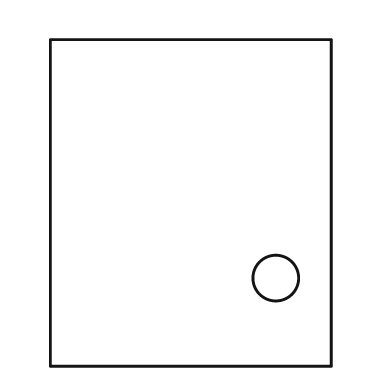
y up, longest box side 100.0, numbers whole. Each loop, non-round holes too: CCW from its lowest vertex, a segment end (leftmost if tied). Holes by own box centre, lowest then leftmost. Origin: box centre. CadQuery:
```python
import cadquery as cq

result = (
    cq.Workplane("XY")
    .moveTo(-43.0, -50.0)
    .lineTo(43.0, -50.0)
    .lineTo(43.0, 50.0)
    .lineTo(-43.0, 50.0)
    .close()
    .moveTo(26.0, -23.0)
    .circle(7.0)
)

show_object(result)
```